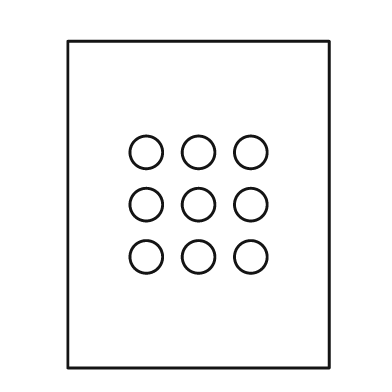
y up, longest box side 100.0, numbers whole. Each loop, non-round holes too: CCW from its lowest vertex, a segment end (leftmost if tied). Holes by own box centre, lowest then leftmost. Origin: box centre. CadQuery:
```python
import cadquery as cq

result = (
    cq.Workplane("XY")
    .moveTo(-40.0, -50.0)
    .lineTo(40.0, -50.0)
    .lineTo(40.0, 50.0)
    .lineTo(-40.0, 50.0)
    .close()
    .moveTo(-16.0, -16.0)
    .circle(5.0)
    .moveTo(0.0, -16.0)
    .circle(5.0)
    .moveTo(16.0, -16.0)
    .circle(5.0)
    .moveTo(-16.0, 0.0)
    .circle(5.0)
    .moveTo(0.0, 0.0)
    .circle(5.0)
    .moveTo(16.0, 0.0)
    .circle(5.0)
    .moveTo(-16.0, 16.0)
    .circle(5.0)
    .moveTo(0.0, 16.0)
    .circle(5.0)
    .moveTo(16.0, 16.0)
    .circle(5.0)
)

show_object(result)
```